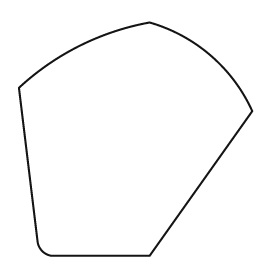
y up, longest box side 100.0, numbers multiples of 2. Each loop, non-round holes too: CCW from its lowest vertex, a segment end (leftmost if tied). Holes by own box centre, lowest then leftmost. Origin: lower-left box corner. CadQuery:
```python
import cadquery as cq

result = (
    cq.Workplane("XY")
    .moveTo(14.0, 0.0)
    .lineTo(56.0, 0.0)
    .lineTo(100.0, 62.0)
    .threePointArc((82.0, 86.0), (56.0, 100.0))
    .threePointArc((26.0, 90.0), (0.0, 72.0))
    .lineTo(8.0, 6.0)
    .threePointArc((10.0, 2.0), (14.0, 0.0))
    .close()
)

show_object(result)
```